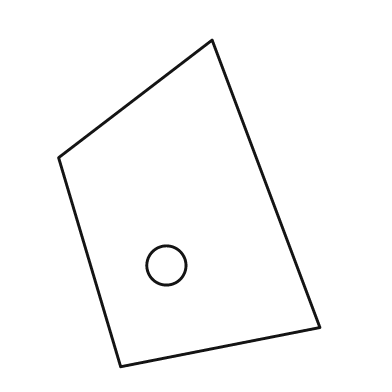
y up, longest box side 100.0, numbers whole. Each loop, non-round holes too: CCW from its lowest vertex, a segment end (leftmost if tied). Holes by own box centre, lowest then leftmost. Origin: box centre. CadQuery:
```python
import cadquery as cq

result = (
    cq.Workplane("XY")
    .moveTo(-21.0, -50.0)
    .lineTo(40.0, -38.0)
    .lineTo(7.0, 50.0)
    .lineTo(-40.0, 14.0)
    .close()
    .moveTo(-7.0, -19.0)
    .circle(6.0)
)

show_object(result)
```